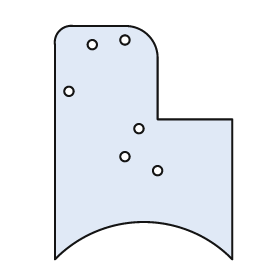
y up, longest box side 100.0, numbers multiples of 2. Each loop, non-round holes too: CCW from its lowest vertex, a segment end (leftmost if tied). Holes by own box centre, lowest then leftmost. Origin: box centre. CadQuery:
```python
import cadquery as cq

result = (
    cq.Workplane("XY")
    .moveTo(-38.0, -50.0)
    .threePointArc((0.0, -34.0), (38.0, -50.0))
    .lineTo(38.0, 10.0)
    .lineTo(6.0, 10.0)
    .lineTo(6.0, 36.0)
    .threePointArc((2.0, 46.0), (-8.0, 50.0))
    .lineTo(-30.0, 50.0)
    .threePointArc((-36.0, 48.0), (-38.0, 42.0))
    .close()
    .moveTo(6.0, -12.0)
    .circle(2.0)
    .moveTo(-8.0, -6.0)
    .circle(2.0)
    .moveTo(-2.0, 6.0)
    .circle(2.0)
    .moveTo(-32.0, 22.0)
    .circle(2.0)
    .moveTo(-22.0, 42.0)
    .circle(2.0)
    .moveTo(-8.0, 44.0)
    .circle(2.0)
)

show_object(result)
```